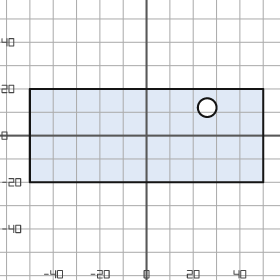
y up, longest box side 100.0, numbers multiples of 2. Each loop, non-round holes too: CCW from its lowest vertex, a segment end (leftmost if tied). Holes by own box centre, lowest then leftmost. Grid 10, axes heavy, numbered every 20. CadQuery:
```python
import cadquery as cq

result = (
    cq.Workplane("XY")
    .moveTo(-50.0, -20.0)
    .lineTo(50.0, -20.0)
    .lineTo(50.0, 20.0)
    .lineTo(-50.0, 20.0)
    .close()
    .moveTo(26.0, 12.0)
    .circle(4.0)
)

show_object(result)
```